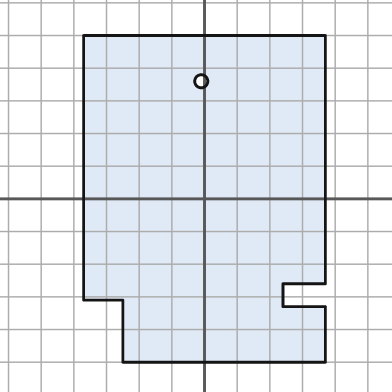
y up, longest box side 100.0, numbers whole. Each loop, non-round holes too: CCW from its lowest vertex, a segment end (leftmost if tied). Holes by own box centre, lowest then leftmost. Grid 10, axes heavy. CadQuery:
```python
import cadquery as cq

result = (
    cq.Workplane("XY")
    .moveTo(-25.0, -50.0)
    .lineTo(37.0, -50.0)
    .lineTo(37.0, -33.0)
    .lineTo(24.0, -33.0)
    .lineTo(24.0, -26.0)
    .lineTo(37.0, -26.0)
    .lineTo(37.0, 50.0)
    .lineTo(-37.0, 50.0)
    .lineTo(-37.0, -31.0)
    .lineTo(-25.0, -31.0)
    .close()
    .moveTo(-1.0, 36.0)
    .circle(2.0)
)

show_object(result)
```